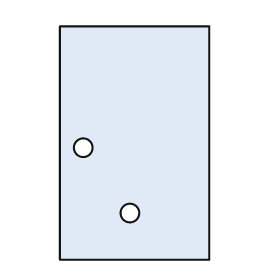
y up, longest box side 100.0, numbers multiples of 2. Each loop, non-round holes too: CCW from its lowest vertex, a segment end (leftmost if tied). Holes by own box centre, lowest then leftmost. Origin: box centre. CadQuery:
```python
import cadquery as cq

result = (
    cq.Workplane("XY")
    .moveTo(-32.0, -50.0)
    .lineTo(32.0, -50.0)
    .lineTo(32.0, 50.0)
    .lineTo(-32.0, 50.0)
    .close()
    .moveTo(-2.0, -30.0)
    .circle(4.0)
    .moveTo(-22.0, -2.0)
    .circle(4.0)
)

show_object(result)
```